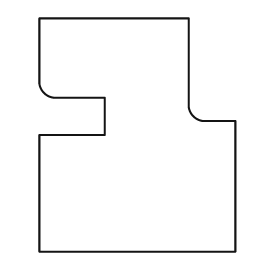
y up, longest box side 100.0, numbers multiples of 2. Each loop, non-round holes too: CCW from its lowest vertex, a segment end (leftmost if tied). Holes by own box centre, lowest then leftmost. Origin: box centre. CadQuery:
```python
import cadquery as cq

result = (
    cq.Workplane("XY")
    .moveTo(-42.0, -50.0)
    .lineTo(42.0, -50.0)
    .lineTo(42.0, 6.0)
    .lineTo(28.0, 6.0)
    .threePointArc((24.0, 8.0), (22.0, 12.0))
    .lineTo(22.0, 50.0)
    .lineTo(-42.0, 50.0)
    .lineTo(-42.0, 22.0)
    .threePointArc((-40.0, 18.0), (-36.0, 16.0))
    .lineTo(-14.0, 16.0)
    .lineTo(-14.0, 0.0)
    .lineTo(-42.0, 0.0)
    .close()
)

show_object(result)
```